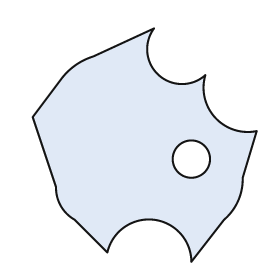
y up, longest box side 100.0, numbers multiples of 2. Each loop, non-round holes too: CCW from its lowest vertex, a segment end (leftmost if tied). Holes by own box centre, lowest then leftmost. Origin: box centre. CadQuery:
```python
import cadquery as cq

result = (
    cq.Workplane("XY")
    .moveTo(20.0, -50.0)
    .lineTo(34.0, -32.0)
    .threePointArc((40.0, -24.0), (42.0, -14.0))
    .lineTo(48.0, 6.0)
    .threePointArc((30.0, 12.0), (26.0, 30.0))
    .threePointArc((6.0, 30.0), (4.0, 50.0))
    .lineTo(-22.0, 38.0)
    .threePointArc((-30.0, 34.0), (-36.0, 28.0))
    .lineTo(-48.0, 12.0)
    .lineTo(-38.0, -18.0)
    .threePointArc((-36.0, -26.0), (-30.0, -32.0))
    .lineTo(-16.0, -46.0)
    .threePointArc((4.0, -32.0), (20.0, -50.0))
    .close()
    .moveTo(20.0, -6.0)
    .circle(8.0)
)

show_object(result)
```